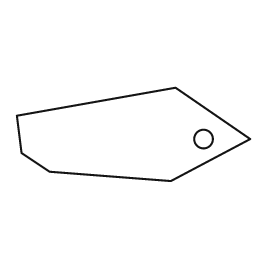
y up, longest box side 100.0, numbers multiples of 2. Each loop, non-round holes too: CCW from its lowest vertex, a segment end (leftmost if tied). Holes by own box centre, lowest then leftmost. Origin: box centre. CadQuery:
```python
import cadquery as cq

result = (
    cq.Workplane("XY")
    .moveTo(16.0, -20.0)
    .lineTo(50.0, -2.0)
    .lineTo(18.0, 20.0)
    .lineTo(-50.0, 8.0)
    .lineTo(-48.0, -8.0)
    .lineTo(-36.0, -16.0)
    .close()
    .moveTo(30.0, -2.0)
    .circle(4.0)
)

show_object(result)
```